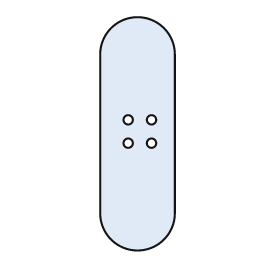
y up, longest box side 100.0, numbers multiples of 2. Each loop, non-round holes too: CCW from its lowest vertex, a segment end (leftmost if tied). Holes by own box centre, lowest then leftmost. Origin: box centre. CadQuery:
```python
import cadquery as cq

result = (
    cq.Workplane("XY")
    .moveTo(-16.0, -34.0)
    .threePointArc((0.0, -50.0), (16.0, -34.0))
    .lineTo(16.0, 34.0)
    .threePointArc((0.0, 50.0), (-16.0, 34.0))
    .close()
    .moveTo(-4.0, -4.0)
    .circle(2.0)
    .moveTo(6.0, -4.0)
    .circle(2.0)
    .moveTo(-4.0, 6.0)
    .circle(2.0)
    .moveTo(6.0, 6.0)
    .circle(2.0)
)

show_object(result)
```